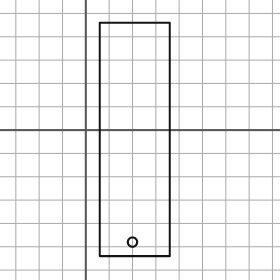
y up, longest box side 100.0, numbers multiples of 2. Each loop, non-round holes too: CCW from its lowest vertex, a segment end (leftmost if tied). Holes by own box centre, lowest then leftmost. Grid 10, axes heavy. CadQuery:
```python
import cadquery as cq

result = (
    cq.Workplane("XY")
    .moveTo(6.0, -54.0)
    .lineTo(36.0, -54.0)
    .lineTo(36.0, 46.0)
    .lineTo(6.0, 46.0)
    .close()
    .moveTo(20.0, -48.0)
    .circle(2.0)
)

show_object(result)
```